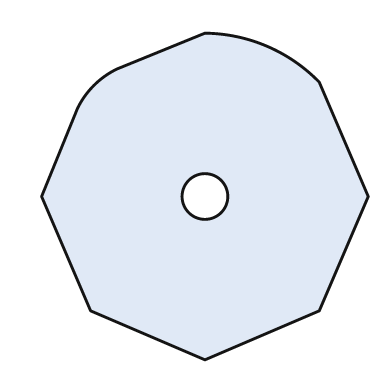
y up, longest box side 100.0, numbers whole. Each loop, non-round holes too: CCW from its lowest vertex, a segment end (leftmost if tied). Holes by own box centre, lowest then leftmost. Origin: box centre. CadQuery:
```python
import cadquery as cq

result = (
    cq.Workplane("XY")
    .moveTo(0.0, -50.0)
    .lineTo(35.0, -35.0)
    .lineTo(50.0, 0.0)
    .lineTo(35.0, 35.0)
    .threePointArc((19.0, 46.0), (0.0, 50.0))
    .lineTo(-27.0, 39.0)
    .threePointArc((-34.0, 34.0), (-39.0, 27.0))
    .lineTo(-50.0, 0.0)
    .lineTo(-35.0, -35.0)
    .close()
    .moveTo(0.0, 0.0)
    .circle(7.0)
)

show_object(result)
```